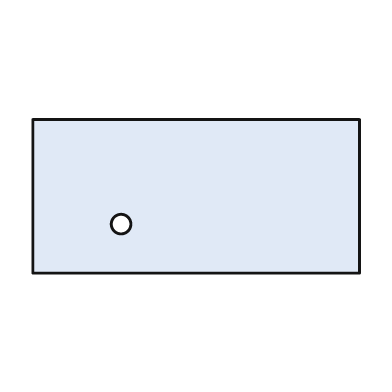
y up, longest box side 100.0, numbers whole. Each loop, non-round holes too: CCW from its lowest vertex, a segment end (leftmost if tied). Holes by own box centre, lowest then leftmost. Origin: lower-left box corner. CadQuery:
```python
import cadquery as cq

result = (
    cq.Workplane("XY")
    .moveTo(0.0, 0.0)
    .lineTo(100.0, 0.0)
    .lineTo(100.0, 47.0)
    .lineTo(0.0, 47.0)
    .close()
    .moveTo(27.0, 15.0)
    .circle(3.0)
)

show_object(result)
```